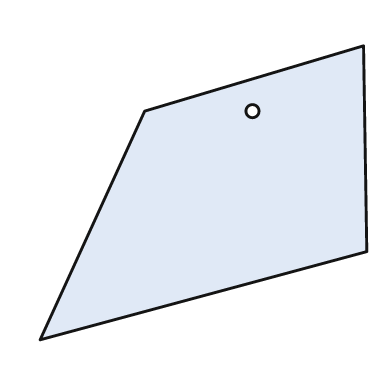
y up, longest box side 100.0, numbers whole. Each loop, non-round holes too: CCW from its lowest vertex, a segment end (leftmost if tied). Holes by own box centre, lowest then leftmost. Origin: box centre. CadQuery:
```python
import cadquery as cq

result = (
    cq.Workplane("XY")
    .moveTo(-50.0, -45.0)
    .lineTo(50.0, -18.0)
    .lineTo(49.0, 45.0)
    .lineTo(-18.0, 25.0)
    .close()
    .moveTo(15.0, 25.0)
    .circle(2.0)
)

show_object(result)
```